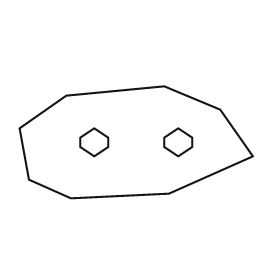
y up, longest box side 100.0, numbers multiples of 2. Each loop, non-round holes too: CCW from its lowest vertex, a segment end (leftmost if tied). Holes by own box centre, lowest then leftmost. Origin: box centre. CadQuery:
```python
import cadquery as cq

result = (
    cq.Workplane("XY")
    .moveTo(-28.0, -24.0)
    .lineTo(14.0, -22.0)
    .lineTo(50.0, -6.0)
    .lineTo(36.0, 14.0)
    .lineTo(12.0, 24.0)
    .lineTo(-30.0, 20.0)
    .lineTo(-50.0, 6.0)
    .lineTo(-46.0, -16.0)
    .close()
    .moveTo(-18.0, -6.0)
    .lineTo(-12.0, -2.0)
    .lineTo(-12.0, 2.0)
    .lineTo(-18.0, 6.0)
    .lineTo(-24.0, 2.0)
    .lineTo(-24.0, -2.0)
    .close()
    .moveTo(18.0, -6.0)
    .lineTo(24.0, -2.0)
    .lineTo(24.0, 2.0)
    .lineTo(18.0, 6.0)
    .lineTo(12.0, 2.0)
    .lineTo(12.0, -2.0)
    .close()
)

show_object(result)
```